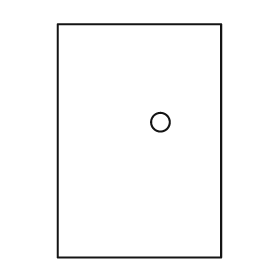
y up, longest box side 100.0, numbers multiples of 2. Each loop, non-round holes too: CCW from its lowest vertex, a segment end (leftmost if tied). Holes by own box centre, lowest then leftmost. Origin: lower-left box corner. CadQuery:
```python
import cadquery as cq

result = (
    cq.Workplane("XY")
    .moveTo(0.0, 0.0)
    .lineTo(70.0, 0.0)
    .lineTo(70.0, 100.0)
    .lineTo(0.0, 100.0)
    .close()
    .moveTo(44.0, 58.0)
    .circle(4.0)
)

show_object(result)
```